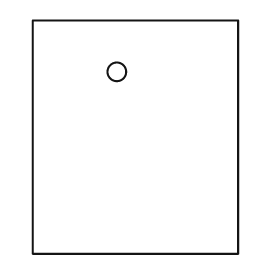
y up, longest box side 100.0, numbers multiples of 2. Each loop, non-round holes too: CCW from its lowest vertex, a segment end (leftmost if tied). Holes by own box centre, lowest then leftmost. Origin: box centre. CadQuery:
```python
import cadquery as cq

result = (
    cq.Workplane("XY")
    .moveTo(-44.0, -50.0)
    .lineTo(44.0, -50.0)
    .lineTo(44.0, 50.0)
    .lineTo(-44.0, 50.0)
    .close()
    .moveTo(-8.0, 28.0)
    .circle(4.0)
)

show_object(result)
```